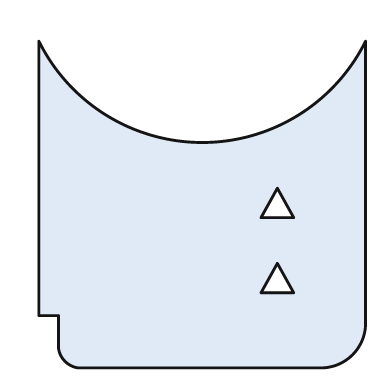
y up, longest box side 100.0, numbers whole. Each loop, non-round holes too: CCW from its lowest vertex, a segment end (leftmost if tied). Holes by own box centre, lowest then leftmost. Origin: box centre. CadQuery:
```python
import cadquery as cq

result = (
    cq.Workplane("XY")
    .moveTo(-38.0, -50.0)
    .lineTo(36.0, -50.0)
    .threePointArc((46.0, -46.0), (50.0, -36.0))
    .lineTo(50.0, 50.0)
    .threePointArc((0.0, 19.0), (-50.0, 50.0))
    .lineTo(-50.0, -34.0)
    .lineTo(-44.0, -34.0)
    .lineTo(-44.0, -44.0)
    .threePointArc((-42.0, -48.0), (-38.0, -50.0))
    .close()
    .moveTo(18.0, -27.0)
    .lineTo(28.0, -27.0)
    .lineTo(23.0, -18.0)
    .close()
    .moveTo(18.0, -4.0)
    .lineTo(28.0, -4.0)
    .lineTo(23.0, 5.0)
    .close()
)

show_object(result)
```